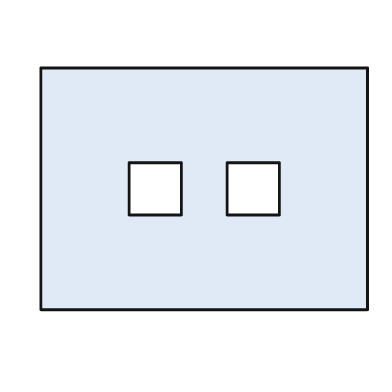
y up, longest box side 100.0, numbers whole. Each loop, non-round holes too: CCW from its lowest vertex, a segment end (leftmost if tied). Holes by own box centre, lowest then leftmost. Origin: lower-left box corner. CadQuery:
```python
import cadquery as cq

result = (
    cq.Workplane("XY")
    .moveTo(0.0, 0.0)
    .lineTo(100.0, 0.0)
    .lineTo(100.0, 74.0)
    .lineTo(0.0, 74.0)
    .close()
    .moveTo(27.0, 29.0)
    .lineTo(43.0, 29.0)
    .lineTo(43.0, 45.0)
    .lineTo(27.0, 45.0)
    .close()
    .moveTo(57.0, 29.0)
    .lineTo(73.0, 29.0)
    .lineTo(73.0, 45.0)
    .lineTo(57.0, 45.0)
    .close()
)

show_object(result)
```